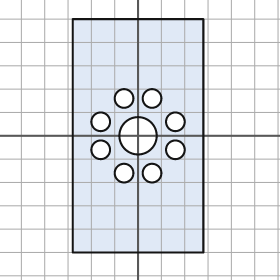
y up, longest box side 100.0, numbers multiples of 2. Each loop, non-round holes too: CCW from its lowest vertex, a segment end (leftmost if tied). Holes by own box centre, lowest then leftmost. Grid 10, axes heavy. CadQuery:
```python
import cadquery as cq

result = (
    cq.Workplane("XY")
    .moveTo(-28.0, -50.0)
    .lineTo(28.0, -50.0)
    .lineTo(28.0, 50.0)
    .lineTo(-28.0, 50.0)
    .close()
    .moveTo(-6.0, -16.0)
    .circle(4.0)
    .moveTo(6.0, -16.0)
    .circle(4.0)
    .moveTo(-16.0, -6.0)
    .circle(4.0)
    .moveTo(16.0, -6.0)
    .circle(4.0)
    .moveTo(0.0, 0.0)
    .circle(8.0)
    .moveTo(-16.0, 6.0)
    .circle(4.0)
    .moveTo(16.0, 6.0)
    .circle(4.0)
    .moveTo(-6.0, 16.0)
    .circle(4.0)
    .moveTo(6.0, 16.0)
    .circle(4.0)
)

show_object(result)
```